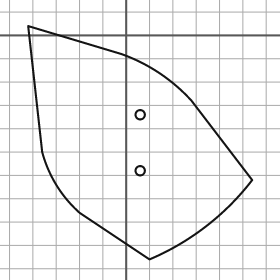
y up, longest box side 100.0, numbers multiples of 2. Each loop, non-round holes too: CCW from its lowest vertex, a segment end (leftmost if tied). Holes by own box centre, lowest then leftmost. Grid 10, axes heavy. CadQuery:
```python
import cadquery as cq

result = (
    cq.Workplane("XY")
    .moveTo(10.0, -96.0)
    .threePointArc((34.0, -82.0), (54.0, -62.0))
    .lineTo(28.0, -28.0)
    .threePointArc((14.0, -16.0), (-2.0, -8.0))
    .lineTo(-42.0, 4.0)
    .lineTo(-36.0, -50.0)
    .threePointArc((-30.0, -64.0), (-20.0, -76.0))
    .close()
    .moveTo(6.0, -58.0)
    .circle(2.0)
    .moveTo(6.0, -34.0)
    .circle(2.0)
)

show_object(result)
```